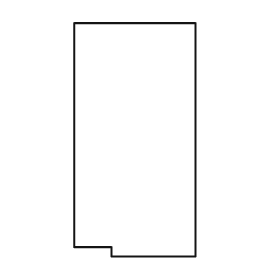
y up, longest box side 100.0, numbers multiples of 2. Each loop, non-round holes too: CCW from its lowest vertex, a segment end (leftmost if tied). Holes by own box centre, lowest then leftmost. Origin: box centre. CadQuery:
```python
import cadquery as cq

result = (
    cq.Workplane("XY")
    .moveTo(-10.0, -50.0)
    .lineTo(26.0, -50.0)
    .lineTo(26.0, 50.0)
    .lineTo(-26.0, 50.0)
    .lineTo(-26.0, -46.0)
    .lineTo(-10.0, -46.0)
    .close()
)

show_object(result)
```